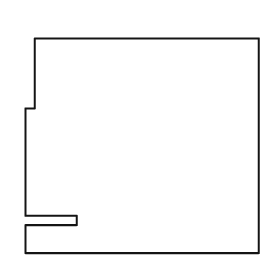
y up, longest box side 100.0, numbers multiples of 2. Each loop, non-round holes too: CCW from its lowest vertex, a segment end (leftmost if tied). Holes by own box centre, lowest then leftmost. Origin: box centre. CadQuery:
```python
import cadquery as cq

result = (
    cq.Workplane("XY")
    .moveTo(-50.0, -46.0)
    .lineTo(50.0, -46.0)
    .lineTo(50.0, 46.0)
    .lineTo(-46.0, 46.0)
    .lineTo(-46.0, 16.0)
    .lineTo(-50.0, 16.0)
    .lineTo(-50.0, -30.0)
    .lineTo(-28.0, -30.0)
    .lineTo(-28.0, -34.0)
    .lineTo(-50.0, -34.0)
    .close()
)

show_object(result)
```